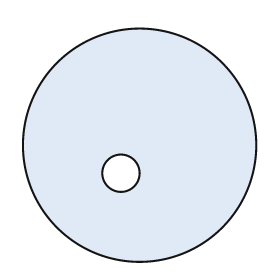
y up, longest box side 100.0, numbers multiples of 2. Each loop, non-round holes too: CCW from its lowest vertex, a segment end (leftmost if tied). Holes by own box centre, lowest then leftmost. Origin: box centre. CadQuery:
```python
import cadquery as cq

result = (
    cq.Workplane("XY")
    .moveTo(0.0, 0.0)
    .circle(50.0)
    .moveTo(-8.0, -12.0)
    .circle(8.0)
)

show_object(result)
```